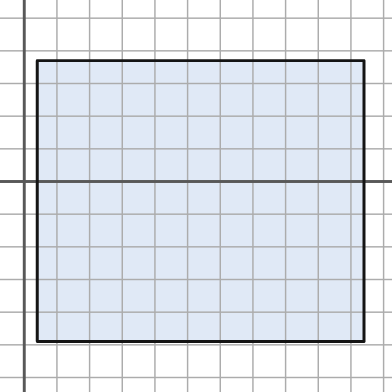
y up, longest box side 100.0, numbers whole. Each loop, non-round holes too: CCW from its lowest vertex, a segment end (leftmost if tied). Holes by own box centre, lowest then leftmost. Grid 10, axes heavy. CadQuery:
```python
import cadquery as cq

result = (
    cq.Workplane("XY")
    .moveTo(4.0, -49.0)
    .lineTo(104.0, -49.0)
    .lineTo(104.0, 37.0)
    .lineTo(4.0, 37.0)
    .close()
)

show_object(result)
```